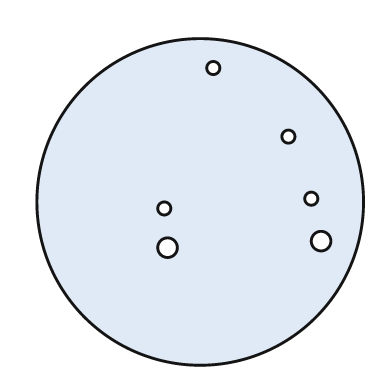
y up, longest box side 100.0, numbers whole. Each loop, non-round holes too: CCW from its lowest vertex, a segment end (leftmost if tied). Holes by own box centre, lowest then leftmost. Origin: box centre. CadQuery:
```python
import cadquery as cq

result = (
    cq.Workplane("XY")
    .moveTo(0.0, 0.0)
    .circle(50.0)
    .moveTo(-10.0, -14.0)
    .circle(3.0)
    .moveTo(37.0, -12.0)
    .circle(3.0)
    .moveTo(-11.0, -2.0)
    .circle(2.0)
    .moveTo(34.0, 1.0)
    .circle(2.0)
    .moveTo(27.0, 20.0)
    .circle(2.0)
    .moveTo(4.0, 41.0)
    .circle(2.0)
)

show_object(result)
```